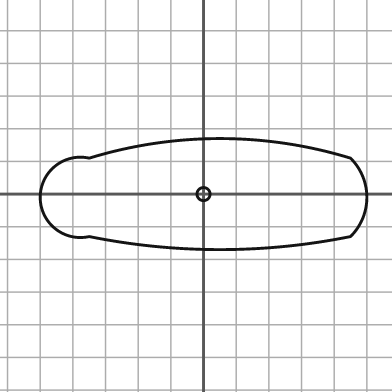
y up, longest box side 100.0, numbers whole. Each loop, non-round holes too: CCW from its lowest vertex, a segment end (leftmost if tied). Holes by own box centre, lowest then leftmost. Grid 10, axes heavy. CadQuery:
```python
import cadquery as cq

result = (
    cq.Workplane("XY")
    .moveTo(-35.0, -13.0)
    .threePointArc((5.0, -17.0), (45.0, -13.0))
    .threePointArc((50.0, -1.0), (45.0, 11.0))
    .threePointArc((5.0, 17.0), (-35.0, 11.0))
    .threePointArc((-50.0, -1.0), (-35.0, -13.0))
    .close()
    .moveTo(0.0, 0.0)
    .circle(2.0)
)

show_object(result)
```